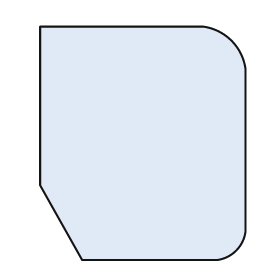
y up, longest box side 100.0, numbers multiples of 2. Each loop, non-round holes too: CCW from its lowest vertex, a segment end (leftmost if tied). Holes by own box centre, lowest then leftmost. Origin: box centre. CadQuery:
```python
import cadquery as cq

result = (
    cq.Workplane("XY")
    .moveTo(-26.0, -50.0)
    .lineTo(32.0, -50.0)
    .threePointArc((40.0, -46.0), (44.0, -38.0))
    .lineTo(44.0, 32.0)
    .threePointArc((38.0, 44.0), (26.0, 50.0))
    .lineTo(-44.0, 50.0)
    .lineTo(-44.0, -18.0)
    .close()
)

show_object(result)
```